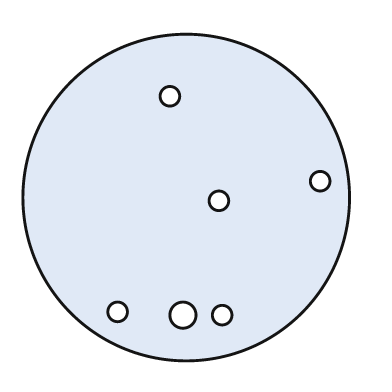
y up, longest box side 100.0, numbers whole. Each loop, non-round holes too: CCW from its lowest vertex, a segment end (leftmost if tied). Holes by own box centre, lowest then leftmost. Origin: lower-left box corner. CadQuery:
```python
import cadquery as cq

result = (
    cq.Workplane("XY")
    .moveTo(50.0, 50.0)
    .circle(50.0)
    .moveTo(49.0, 14.0)
    .circle(4.0)
    .moveTo(61.0, 14.0)
    .circle(3.0)
    .moveTo(29.0, 15.0)
    .circle(3.0)
    .moveTo(60.0, 49.0)
    .circle(3.0)
    .moveTo(91.0, 55.0)
    .circle(3.0)
    .moveTo(45.0, 81.0)
    .circle(3.0)
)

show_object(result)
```